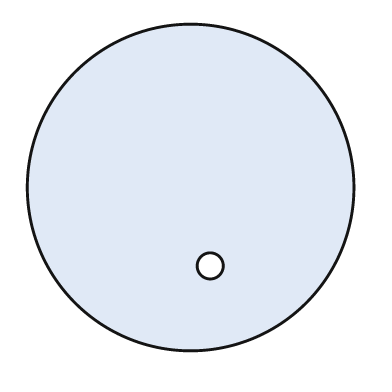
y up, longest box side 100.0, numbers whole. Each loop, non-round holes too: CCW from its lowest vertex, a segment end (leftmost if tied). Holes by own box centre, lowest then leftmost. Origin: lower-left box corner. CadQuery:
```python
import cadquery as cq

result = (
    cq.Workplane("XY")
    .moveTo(50.0, 50.0)
    .circle(50.0)
    .moveTo(56.0, 26.0)
    .circle(4.0)
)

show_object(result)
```